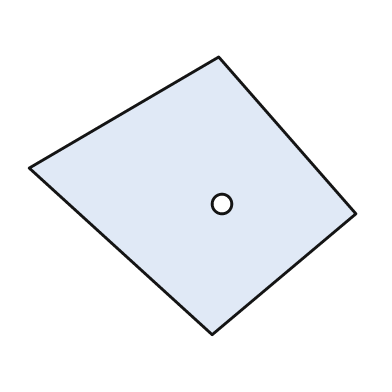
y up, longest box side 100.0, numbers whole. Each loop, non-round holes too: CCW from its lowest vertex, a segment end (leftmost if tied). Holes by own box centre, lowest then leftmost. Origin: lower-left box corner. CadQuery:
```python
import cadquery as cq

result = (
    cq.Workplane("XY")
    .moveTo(56.0, 0.0)
    .lineTo(100.0, 37.0)
    .lineTo(58.0, 85.0)
    .lineTo(0.0, 51.0)
    .close()
    .moveTo(59.0, 40.0)
    .circle(3.0)
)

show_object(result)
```